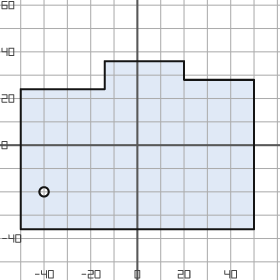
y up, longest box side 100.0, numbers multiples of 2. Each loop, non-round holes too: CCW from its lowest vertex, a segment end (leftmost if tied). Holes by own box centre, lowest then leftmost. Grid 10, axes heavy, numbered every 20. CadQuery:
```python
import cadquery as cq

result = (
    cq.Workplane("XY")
    .moveTo(-50.0, -36.0)
    .lineTo(50.0, -36.0)
    .lineTo(50.0, 28.0)
    .lineTo(20.0, 28.0)
    .lineTo(20.0, 36.0)
    .lineTo(-14.0, 36.0)
    .lineTo(-14.0, 24.0)
    .lineTo(-50.0, 24.0)
    .close()
    .moveTo(-40.0, -20.0)
    .circle(2.0)
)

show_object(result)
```